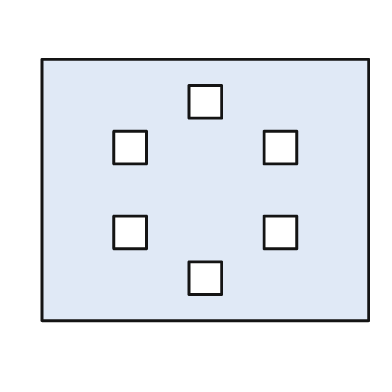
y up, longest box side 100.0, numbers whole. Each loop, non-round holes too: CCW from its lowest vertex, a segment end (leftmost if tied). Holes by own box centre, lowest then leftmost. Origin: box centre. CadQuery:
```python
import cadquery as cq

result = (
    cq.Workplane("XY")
    .moveTo(-50.0, -40.0)
    .lineTo(50.0, -40.0)
    .lineTo(50.0, 40.0)
    .lineTo(-50.0, 40.0)
    .close()
    .moveTo(-5.0, -32.0)
    .lineTo(5.0, -32.0)
    .lineTo(5.0, -22.0)
    .lineTo(-5.0, -22.0)
    .close()
    .moveTo(-28.0, -18.0)
    .lineTo(-18.0, -18.0)
    .lineTo(-18.0, -8.0)
    .lineTo(-28.0, -8.0)
    .close()
    .moveTo(18.0, -18.0)
    .lineTo(28.0, -18.0)
    .lineTo(28.0, -8.0)
    .lineTo(18.0, -8.0)
    .close()
    .moveTo(-28.0, 8.0)
    .lineTo(-18.0, 8.0)
    .lineTo(-18.0, 18.0)
    .lineTo(-28.0, 18.0)
    .close()
    .moveTo(18.0, 8.0)
    .lineTo(28.0, 8.0)
    .lineTo(28.0, 18.0)
    .lineTo(18.0, 18.0)
    .close()
    .moveTo(-5.0, 22.0)
    .lineTo(5.0, 22.0)
    .lineTo(5.0, 32.0)
    .lineTo(-5.0, 32.0)
    .close()
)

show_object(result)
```